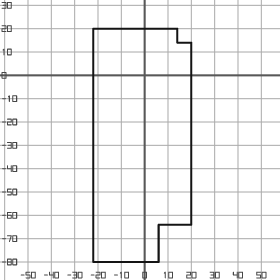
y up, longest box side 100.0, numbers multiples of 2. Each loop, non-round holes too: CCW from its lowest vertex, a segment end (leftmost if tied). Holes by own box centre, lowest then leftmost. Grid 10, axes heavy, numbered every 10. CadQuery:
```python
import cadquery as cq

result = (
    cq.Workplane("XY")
    .moveTo(-22.0, -80.0)
    .lineTo(6.0, -80.0)
    .lineTo(6.0, -64.0)
    .lineTo(20.0, -64.0)
    .lineTo(20.0, 14.0)
    .lineTo(14.0, 14.0)
    .lineTo(14.0, 20.0)
    .lineTo(-22.0, 20.0)
    .close()
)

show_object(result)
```